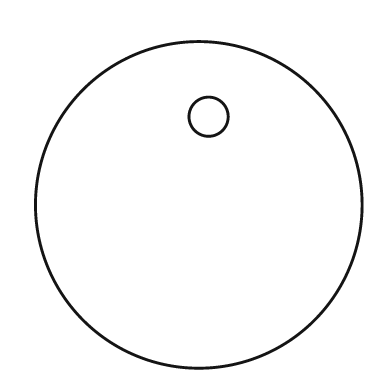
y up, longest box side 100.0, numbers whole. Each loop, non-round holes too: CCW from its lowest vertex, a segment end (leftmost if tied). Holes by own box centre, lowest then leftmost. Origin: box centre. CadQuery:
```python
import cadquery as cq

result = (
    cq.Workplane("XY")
    .moveTo(0.0, 0.0)
    .circle(50.0)
    .moveTo(3.0, 27.0)
    .circle(6.0)
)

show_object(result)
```